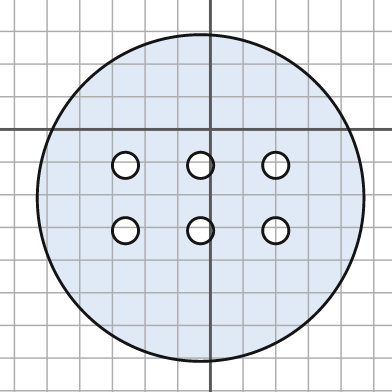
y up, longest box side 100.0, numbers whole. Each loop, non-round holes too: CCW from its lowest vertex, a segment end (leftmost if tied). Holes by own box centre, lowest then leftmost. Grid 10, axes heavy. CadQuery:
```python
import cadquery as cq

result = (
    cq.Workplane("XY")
    .moveTo(-3.0, -21.0)
    .circle(50.0)
    .moveTo(-26.0, -31.0)
    .circle(4.0)
    .moveTo(-3.0, -31.0)
    .circle(4.0)
    .moveTo(20.0, -31.0)
    .circle(4.0)
    .moveTo(-26.0, -11.0)
    .circle(4.0)
    .moveTo(-3.0, -11.0)
    .circle(4.0)
    .moveTo(20.0, -11.0)
    .circle(4.0)
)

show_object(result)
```